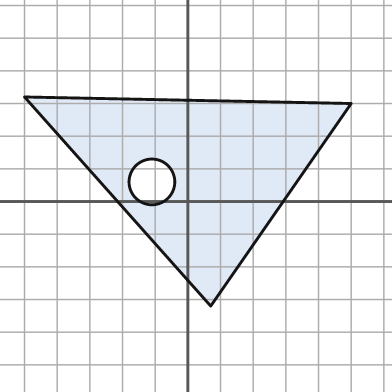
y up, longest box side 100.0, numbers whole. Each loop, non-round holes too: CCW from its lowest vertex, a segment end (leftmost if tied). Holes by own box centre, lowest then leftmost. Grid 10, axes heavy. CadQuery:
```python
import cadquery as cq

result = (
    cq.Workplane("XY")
    .moveTo(7.0, -32.0)
    .lineTo(50.0, 30.0)
    .lineTo(-50.0, 32.0)
    .close()
    .moveTo(-11.0, 6.0)
    .circle(7.0)
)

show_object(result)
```